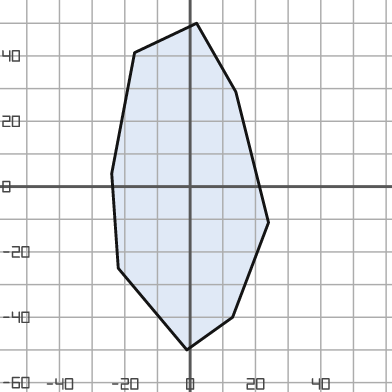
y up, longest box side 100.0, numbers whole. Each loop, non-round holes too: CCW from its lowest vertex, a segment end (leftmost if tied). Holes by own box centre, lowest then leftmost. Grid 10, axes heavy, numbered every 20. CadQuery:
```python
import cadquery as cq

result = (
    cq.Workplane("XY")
    .moveTo(-1.0, -50.0)
    .lineTo(13.0, -40.0)
    .lineTo(24.0, -11.0)
    .lineTo(14.0, 29.0)
    .lineTo(2.0, 50.0)
    .lineTo(-17.0, 41.0)
    .lineTo(-24.0, 4.0)
    .lineTo(-22.0, -25.0)
    .close()
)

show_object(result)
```